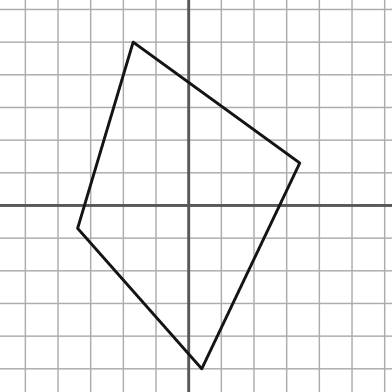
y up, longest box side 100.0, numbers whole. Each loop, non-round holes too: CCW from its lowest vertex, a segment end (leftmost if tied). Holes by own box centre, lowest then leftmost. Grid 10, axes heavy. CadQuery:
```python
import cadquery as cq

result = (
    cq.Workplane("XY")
    .moveTo(4.0, -50.0)
    .lineTo(34.0, 13.0)
    .lineTo(-17.0, 50.0)
    .lineTo(-34.0, -7.0)
    .close()
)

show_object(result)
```